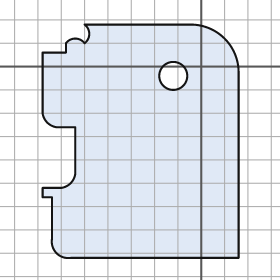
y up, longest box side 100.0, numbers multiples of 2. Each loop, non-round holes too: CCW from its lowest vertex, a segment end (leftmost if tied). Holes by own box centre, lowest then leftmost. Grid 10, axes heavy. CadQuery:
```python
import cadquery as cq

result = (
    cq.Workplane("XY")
    .moveTo(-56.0, -82.0)
    .lineTo(16.0, -82.0)
    .lineTo(16.0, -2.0)
    .threePointArc((10.0, 12.0), (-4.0, 18.0))
    .lineTo(-50.0, 18.0)
    .threePointArc((-48.0, 14.0), (-50.0, 10.0))
    .threePointArc((-54.0, 12.0), (-58.0, 10.0))
    .lineTo(-58.0, 6.0)
    .lineTo(-68.0, 6.0)
    .lineTo(-68.0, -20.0)
    .threePointArc((-66.0, -24.0), (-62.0, -26.0))
    .lineTo(-54.0, -26.0)
    .lineTo(-54.0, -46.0)
    .threePointArc((-56.0, -50.0), (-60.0, -52.0))
    .lineTo(-68.0, -52.0)
    .lineTo(-68.0, -56.0)
    .lineTo(-64.0, -56.0)
    .lineTo(-64.0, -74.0)
    .threePointArc((-62.0, -80.0), (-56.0, -82.0))
    .close()
    .moveTo(-12.0, -4.0)
    .circle(6.0)
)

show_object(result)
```